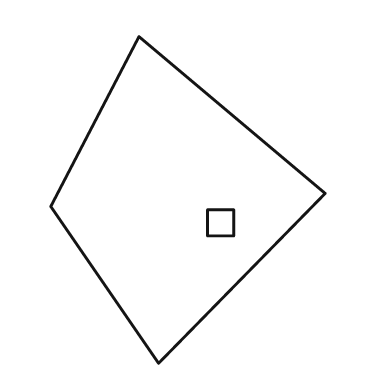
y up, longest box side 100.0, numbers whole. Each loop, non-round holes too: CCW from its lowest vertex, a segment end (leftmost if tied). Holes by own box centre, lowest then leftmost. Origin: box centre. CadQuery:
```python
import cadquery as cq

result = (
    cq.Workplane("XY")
    .moveTo(-9.0, -50.0)
    .lineTo(42.0, 2.0)
    .lineTo(-15.0, 50.0)
    .lineTo(-42.0, -2.0)
    .close()
    .moveTo(6.0, -11.0)
    .lineTo(14.0, -11.0)
    .lineTo(14.0, -3.0)
    .lineTo(6.0, -3.0)
    .close()
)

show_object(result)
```